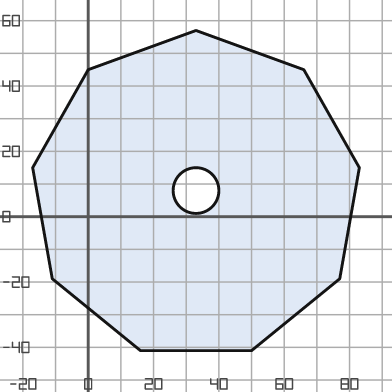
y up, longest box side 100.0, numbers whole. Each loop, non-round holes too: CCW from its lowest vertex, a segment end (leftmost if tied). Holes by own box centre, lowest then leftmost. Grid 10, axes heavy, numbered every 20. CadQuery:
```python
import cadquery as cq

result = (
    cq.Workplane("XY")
    .moveTo(16.0, -41.0)
    .lineTo(50.0, -41.0)
    .lineTo(77.0, -19.0)
    .lineTo(83.0, 15.0)
    .lineTo(66.0, 45.0)
    .lineTo(33.0, 57.0)
    .lineTo(0.0, 45.0)
    .lineTo(-17.0, 15.0)
    .lineTo(-11.0, -19.0)
    .close()
    .moveTo(33.0, 8.0)
    .circle(7.0)
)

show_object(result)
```